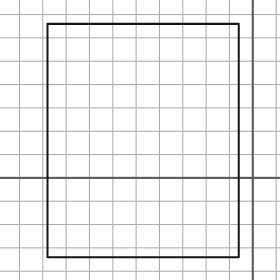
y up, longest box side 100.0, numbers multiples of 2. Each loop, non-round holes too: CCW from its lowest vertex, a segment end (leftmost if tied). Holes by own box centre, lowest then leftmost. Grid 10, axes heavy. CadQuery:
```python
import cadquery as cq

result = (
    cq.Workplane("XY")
    .moveTo(-88.0, -34.0)
    .lineTo(-6.0, -34.0)
    .lineTo(-6.0, 66.0)
    .lineTo(-88.0, 66.0)
    .close()
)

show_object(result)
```